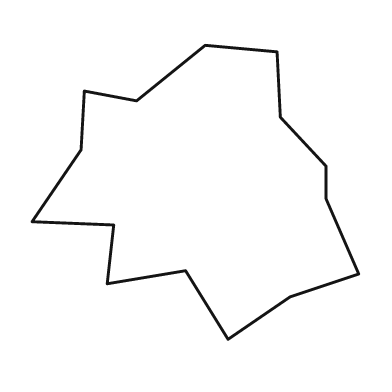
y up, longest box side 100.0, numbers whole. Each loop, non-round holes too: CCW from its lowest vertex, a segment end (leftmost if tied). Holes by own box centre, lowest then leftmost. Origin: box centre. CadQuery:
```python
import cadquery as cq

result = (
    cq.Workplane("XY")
    .moveTo(10.0, -45.0)
    .lineTo(29.0, -32.0)
    .lineTo(50.0, -25.0)
    .lineTo(40.0, -2.0)
    .lineTo(40.0, 8.0)
    .lineTo(26.0, 23.0)
    .lineTo(25.0, 43.0)
    .lineTo(3.0, 45.0)
    .lineTo(-18.0, 28.0)
    .lineTo(-34.0, 31.0)
    .lineTo(-35.0, 13.0)
    .lineTo(-50.0, -9.0)
    .lineTo(-25.0, -10.0)
    .lineTo(-27.0, -28.0)
    .lineTo(-3.0, -24.0)
    .close()
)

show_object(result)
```